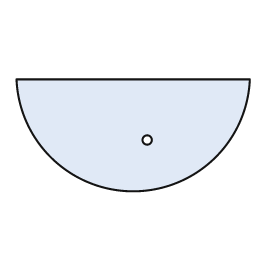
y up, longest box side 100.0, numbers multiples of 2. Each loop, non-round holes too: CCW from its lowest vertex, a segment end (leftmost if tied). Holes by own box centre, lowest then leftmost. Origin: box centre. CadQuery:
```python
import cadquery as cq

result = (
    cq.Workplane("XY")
    .moveTo(-50.0, 24.0)
    .threePointArc((0.0, -24.0), (50.0, 24.0))
    .close()
    .moveTo(6.0, -2.0)
    .circle(2.0)
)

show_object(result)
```